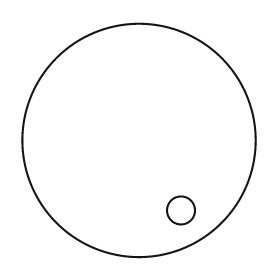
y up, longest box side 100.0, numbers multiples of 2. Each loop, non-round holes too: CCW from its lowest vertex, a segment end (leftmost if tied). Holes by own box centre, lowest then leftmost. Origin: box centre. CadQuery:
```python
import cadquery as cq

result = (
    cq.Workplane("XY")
    .moveTo(0.0, 0.0)
    .circle(50.0)
    .moveTo(18.0, -30.0)
    .circle(6.0)
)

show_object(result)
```